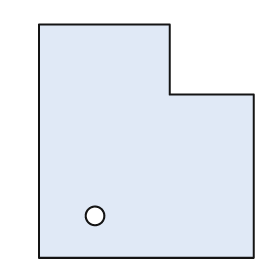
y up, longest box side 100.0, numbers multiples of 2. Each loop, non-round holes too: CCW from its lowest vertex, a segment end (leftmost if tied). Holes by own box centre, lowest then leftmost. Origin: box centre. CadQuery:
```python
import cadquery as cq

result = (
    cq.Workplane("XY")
    .moveTo(-46.0, -50.0)
    .lineTo(46.0, -50.0)
    .lineTo(46.0, 20.0)
    .lineTo(10.0, 20.0)
    .lineTo(10.0, 50.0)
    .lineTo(-46.0, 50.0)
    .close()
    .moveTo(-22.0, -32.0)
    .circle(4.0)
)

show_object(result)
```